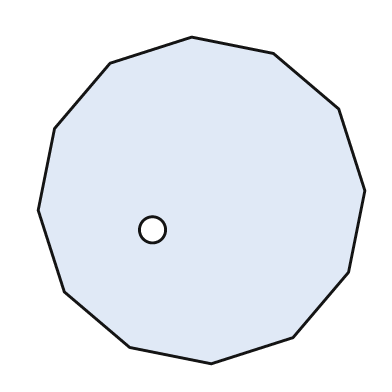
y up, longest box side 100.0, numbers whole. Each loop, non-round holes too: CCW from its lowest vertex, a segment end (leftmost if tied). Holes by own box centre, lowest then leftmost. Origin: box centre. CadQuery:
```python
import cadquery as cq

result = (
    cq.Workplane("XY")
    .moveTo(3.0, -50.0)
    .lineTo(28.0, -42.0)
    .lineTo(45.0, -22.0)
    .lineTo(50.0, 3.0)
    .lineTo(42.0, 28.0)
    .lineTo(22.0, 45.0)
    .lineTo(-3.0, 50.0)
    .lineTo(-28.0, 42.0)
    .lineTo(-45.0, 22.0)
    .lineTo(-50.0, -3.0)
    .lineTo(-42.0, -28.0)
    .lineTo(-22.0, -45.0)
    .close()
    .moveTo(-15.0, -9.0)
    .circle(4.0)
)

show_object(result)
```